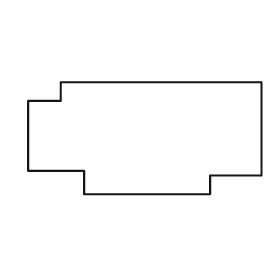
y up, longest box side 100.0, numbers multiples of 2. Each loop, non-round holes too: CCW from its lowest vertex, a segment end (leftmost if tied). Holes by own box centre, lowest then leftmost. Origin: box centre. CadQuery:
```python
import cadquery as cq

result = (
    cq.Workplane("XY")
    .moveTo(-26.0, -24.0)
    .lineTo(28.0, -24.0)
    .lineTo(28.0, -16.0)
    .lineTo(50.0, -16.0)
    .lineTo(50.0, 24.0)
    .lineTo(-36.0, 24.0)
    .lineTo(-36.0, 16.0)
    .lineTo(-50.0, 16.0)
    .lineTo(-50.0, -14.0)
    .lineTo(-26.0, -14.0)
    .close()
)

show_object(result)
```